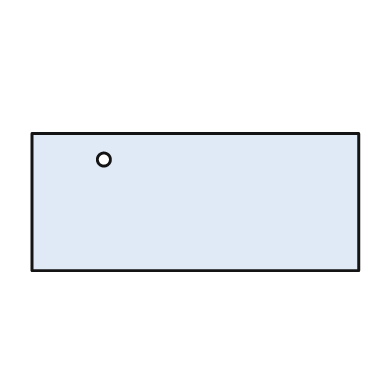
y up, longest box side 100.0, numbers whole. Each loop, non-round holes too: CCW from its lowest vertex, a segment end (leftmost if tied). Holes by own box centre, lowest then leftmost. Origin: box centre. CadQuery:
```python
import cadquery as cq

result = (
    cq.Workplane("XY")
    .moveTo(-50.0, -21.0)
    .lineTo(50.0, -21.0)
    .lineTo(50.0, 21.0)
    .lineTo(-50.0, 21.0)
    .close()
    .moveTo(-28.0, 13.0)
    .circle(2.0)
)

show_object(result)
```